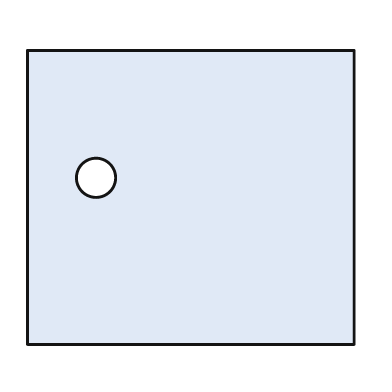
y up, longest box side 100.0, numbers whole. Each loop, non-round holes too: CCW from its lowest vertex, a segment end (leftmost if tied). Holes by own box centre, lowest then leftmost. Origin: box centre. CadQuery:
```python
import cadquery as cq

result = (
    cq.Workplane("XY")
    .moveTo(-50.0, -45.0)
    .lineTo(50.0, -45.0)
    .lineTo(50.0, 45.0)
    .lineTo(-50.0, 45.0)
    .close()
    .moveTo(-29.0, 6.0)
    .circle(6.0)
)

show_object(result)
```